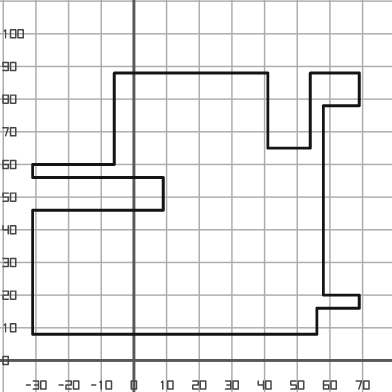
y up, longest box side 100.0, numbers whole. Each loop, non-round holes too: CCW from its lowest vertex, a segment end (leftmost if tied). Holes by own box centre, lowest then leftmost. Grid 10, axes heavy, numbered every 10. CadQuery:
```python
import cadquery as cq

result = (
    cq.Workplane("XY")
    .moveTo(-31.0, 8.0)
    .lineTo(56.0, 8.0)
    .lineTo(56.0, 16.0)
    .lineTo(69.0, 16.0)
    .lineTo(69.0, 20.0)
    .lineTo(58.0, 20.0)
    .lineTo(58.0, 78.0)
    .lineTo(69.0, 78.0)
    .lineTo(69.0, 88.0)
    .lineTo(54.0, 88.0)
    .lineTo(54.0, 65.0)
    .lineTo(41.0, 65.0)
    .lineTo(41.0, 88.0)
    .lineTo(-6.0, 88.0)
    .lineTo(-6.0, 60.0)
    .lineTo(-31.0, 60.0)
    .lineTo(-31.0, 56.0)
    .lineTo(9.0, 56.0)
    .lineTo(9.0, 46.0)
    .lineTo(-31.0, 46.0)
    .close()
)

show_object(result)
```